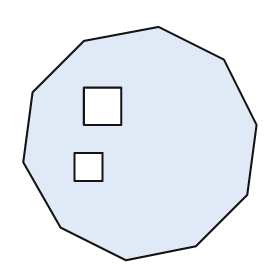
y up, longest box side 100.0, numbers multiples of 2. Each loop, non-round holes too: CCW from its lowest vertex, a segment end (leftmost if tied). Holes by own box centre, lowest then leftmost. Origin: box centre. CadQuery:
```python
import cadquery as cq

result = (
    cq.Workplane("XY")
    .moveTo(-6.0, -50.0)
    .lineTo(24.0, -44.0)
    .lineTo(46.0, -22.0)
    .lineTo(50.0, 8.0)
    .lineTo(36.0, 36.0)
    .lineTo(8.0, 50.0)
    .lineTo(-24.0, 44.0)
    .lineTo(-46.0, 22.0)
    .lineTo(-50.0, -8.0)
    .lineTo(-34.0, -36.0)
    .close()
    .moveTo(-28.0, -16.0)
    .lineTo(-16.0, -16.0)
    .lineTo(-16.0, -4.0)
    .lineTo(-28.0, -4.0)
    .close()
    .moveTo(-24.0, 8.0)
    .lineTo(-8.0, 8.0)
    .lineTo(-8.0, 24.0)
    .lineTo(-24.0, 24.0)
    .close()
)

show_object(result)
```